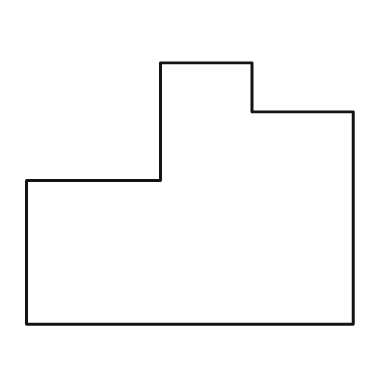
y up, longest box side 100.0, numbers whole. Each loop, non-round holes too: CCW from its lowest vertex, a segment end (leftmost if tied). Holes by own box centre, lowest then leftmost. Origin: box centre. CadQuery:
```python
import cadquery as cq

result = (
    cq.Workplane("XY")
    .moveTo(-50.0, -40.0)
    .lineTo(50.0, -40.0)
    .lineTo(50.0, 25.0)
    .lineTo(19.0, 25.0)
    .lineTo(19.0, 40.0)
    .lineTo(-9.0, 40.0)
    .lineTo(-9.0, 4.0)
    .lineTo(-50.0, 4.0)
    .close()
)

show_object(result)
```